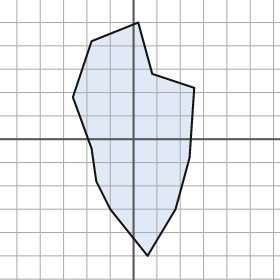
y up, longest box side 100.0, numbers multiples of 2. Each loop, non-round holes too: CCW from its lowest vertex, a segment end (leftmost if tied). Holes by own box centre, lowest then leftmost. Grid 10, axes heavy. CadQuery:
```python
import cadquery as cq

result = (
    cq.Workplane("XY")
    .moveTo(6.0, -50.0)
    .lineTo(18.0, -30.0)
    .lineTo(24.0, -8.0)
    .lineTo(26.0, 22.0)
    .lineTo(8.0, 28.0)
    .lineTo(2.0, 50.0)
    .lineTo(-18.0, 42.0)
    .lineTo(-26.0, 18.0)
    .lineTo(-18.0, -4.0)
    .lineTo(-16.0, -18.0)
    .lineTo(-10.0, -30.0)
    .close()
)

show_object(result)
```